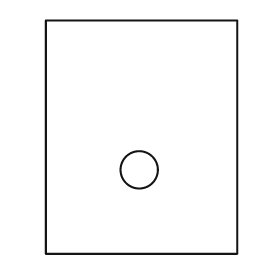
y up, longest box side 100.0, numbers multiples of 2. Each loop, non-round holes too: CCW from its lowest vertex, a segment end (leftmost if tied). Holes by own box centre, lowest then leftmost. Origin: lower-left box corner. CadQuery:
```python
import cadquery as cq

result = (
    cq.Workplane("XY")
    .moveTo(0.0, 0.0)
    .lineTo(82.0, 0.0)
    .lineTo(82.0, 100.0)
    .lineTo(0.0, 100.0)
    .close()
    .moveTo(40.0, 36.0)
    .circle(8.0)
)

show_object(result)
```